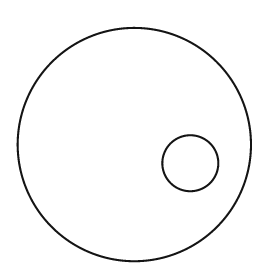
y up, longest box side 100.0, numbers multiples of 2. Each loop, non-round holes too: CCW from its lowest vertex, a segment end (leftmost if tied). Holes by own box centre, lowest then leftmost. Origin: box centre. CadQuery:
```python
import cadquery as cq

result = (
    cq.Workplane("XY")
    .moveTo(0.0, 0.0)
    .circle(50.0)
    .moveTo(24.0, -8.0)
    .circle(12.0)
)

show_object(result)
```